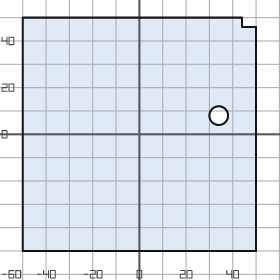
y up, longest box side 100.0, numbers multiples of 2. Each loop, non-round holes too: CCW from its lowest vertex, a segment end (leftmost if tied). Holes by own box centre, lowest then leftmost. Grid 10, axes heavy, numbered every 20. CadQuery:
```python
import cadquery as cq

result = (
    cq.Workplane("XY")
    .moveTo(-50.0, -50.0)
    .lineTo(50.0, -50.0)
    .lineTo(50.0, 46.0)
    .lineTo(44.0, 46.0)
    .lineTo(44.0, 50.0)
    .lineTo(-50.0, 50.0)
    .close()
    .moveTo(34.0, 8.0)
    .circle(4.0)
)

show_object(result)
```